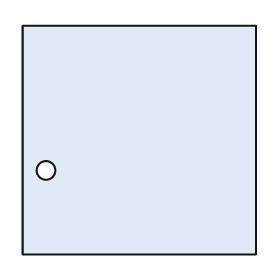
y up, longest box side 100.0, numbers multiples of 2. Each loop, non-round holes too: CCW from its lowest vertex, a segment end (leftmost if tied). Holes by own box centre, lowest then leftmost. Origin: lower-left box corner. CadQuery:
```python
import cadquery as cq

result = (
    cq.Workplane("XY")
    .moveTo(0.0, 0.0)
    .lineTo(100.0, 0.0)
    .lineTo(100.0, 98.0)
    .lineTo(0.0, 98.0)
    .close()
    .moveTo(10.0, 36.0)
    .circle(4.0)
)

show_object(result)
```